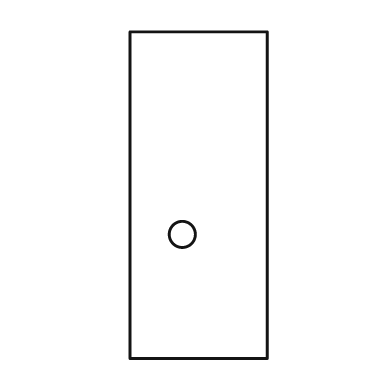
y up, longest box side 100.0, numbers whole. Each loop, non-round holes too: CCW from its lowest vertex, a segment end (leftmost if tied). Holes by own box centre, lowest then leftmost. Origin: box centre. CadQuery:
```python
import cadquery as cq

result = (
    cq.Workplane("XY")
    .moveTo(-21.0, -50.0)
    .lineTo(21.0, -50.0)
    .lineTo(21.0, 50.0)
    .lineTo(-21.0, 50.0)
    .close()
    .moveTo(-5.0, -12.0)
    .circle(4.0)
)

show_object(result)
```